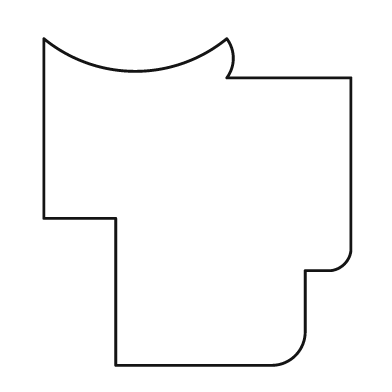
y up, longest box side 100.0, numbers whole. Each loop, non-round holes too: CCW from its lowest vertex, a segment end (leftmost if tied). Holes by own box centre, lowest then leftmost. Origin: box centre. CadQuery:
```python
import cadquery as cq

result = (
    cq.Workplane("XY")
    .moveTo(-25.0, -50.0)
    .lineTo(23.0, -50.0)
    .threePointArc((30.0, -47.0), (33.0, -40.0))
    .lineTo(33.0, -21.0)
    .lineTo(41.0, -21.0)
    .threePointArc((45.0, -19.0), (47.0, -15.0))
    .lineTo(47.0, 38.0)
    .lineTo(9.0, 38.0)
    .threePointArc((11.0, 44.0), (9.0, 50.0))
    .threePointArc((-19.0, 40.0), (-47.0, 50.0))
    .lineTo(-47.0, -5.0)
    .lineTo(-25.0, -5.0)
    .close()
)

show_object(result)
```